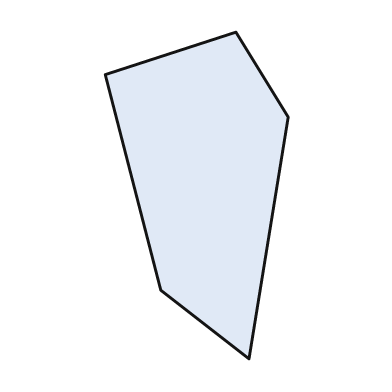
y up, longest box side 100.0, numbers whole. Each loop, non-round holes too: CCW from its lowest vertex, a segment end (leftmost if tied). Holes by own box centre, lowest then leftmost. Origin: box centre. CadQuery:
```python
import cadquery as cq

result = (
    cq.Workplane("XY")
    .moveTo(16.0, -50.0)
    .lineTo(28.0, 24.0)
    .lineTo(12.0, 50.0)
    .lineTo(-28.0, 37.0)
    .lineTo(-11.0, -29.0)
    .close()
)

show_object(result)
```